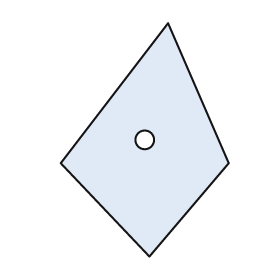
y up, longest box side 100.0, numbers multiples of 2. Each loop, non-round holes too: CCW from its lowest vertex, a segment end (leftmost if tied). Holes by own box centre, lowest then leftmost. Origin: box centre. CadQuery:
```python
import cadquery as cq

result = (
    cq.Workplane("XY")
    .moveTo(2.0, -50.0)
    .lineTo(36.0, -10.0)
    .lineTo(10.0, 50.0)
    .lineTo(-36.0, -10.0)
    .close()
    .moveTo(0.0, 0.0)
    .circle(4.0)
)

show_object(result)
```